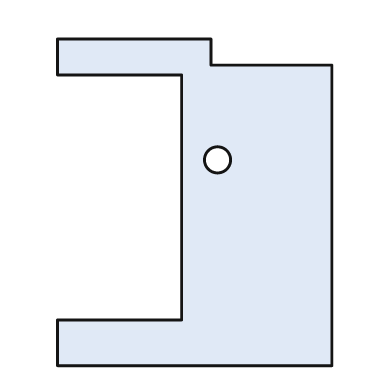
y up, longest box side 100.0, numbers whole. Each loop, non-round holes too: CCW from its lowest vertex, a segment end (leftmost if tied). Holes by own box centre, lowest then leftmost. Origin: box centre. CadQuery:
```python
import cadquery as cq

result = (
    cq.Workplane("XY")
    .moveTo(-42.0, -50.0)
    .lineTo(42.0, -50.0)
    .lineTo(42.0, 42.0)
    .lineTo(5.0, 42.0)
    .lineTo(5.0, 50.0)
    .lineTo(-42.0, 50.0)
    .lineTo(-42.0, 39.0)
    .lineTo(-4.0, 39.0)
    .lineTo(-4.0, -36.0)
    .lineTo(-42.0, -36.0)
    .close()
    .moveTo(7.0, 13.0)
    .circle(4.0)
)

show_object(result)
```